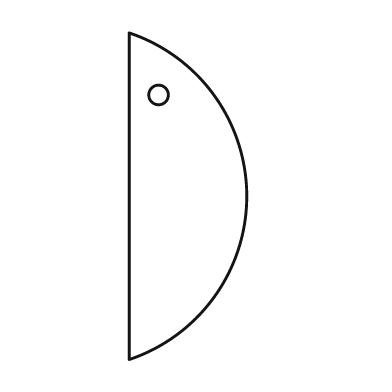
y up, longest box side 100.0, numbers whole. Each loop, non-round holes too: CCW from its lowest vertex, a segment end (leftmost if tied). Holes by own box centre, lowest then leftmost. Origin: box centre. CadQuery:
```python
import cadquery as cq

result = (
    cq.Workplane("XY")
    .moveTo(-18.0, -50.0)
    .threePointArc((18.0, 0.0), (-18.0, 50.0))
    .close()
    .moveTo(-9.0, 31.0)
    .circle(3.0)
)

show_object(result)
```